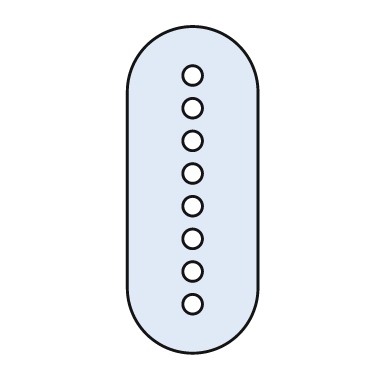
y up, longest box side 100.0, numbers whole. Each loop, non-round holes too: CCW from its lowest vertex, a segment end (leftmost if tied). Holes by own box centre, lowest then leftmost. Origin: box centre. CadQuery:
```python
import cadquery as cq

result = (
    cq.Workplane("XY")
    .moveTo(-20.0, -30.0)
    .threePointArc((0.0, -50.0), (20.0, -30.0))
    .lineTo(20.0, 30.0)
    .threePointArc((0.0, 50.0), (-20.0, 30.0))
    .close()
    .moveTo(0.0, -35.0)
    .circle(3.0)
    .moveTo(0.0, -25.0)
    .circle(3.0)
    .moveTo(0.0, -15.0)
    .circle(3.0)
    .moveTo(0.0, -5.0)
    .circle(3.0)
    .moveTo(0.0, 5.0)
    .circle(3.0)
    .moveTo(0.0, 15.0)
    .circle(3.0)
    .moveTo(0.0, 25.0)
    .circle(3.0)
    .moveTo(0.0, 35.0)
    .circle(3.0)
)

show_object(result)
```